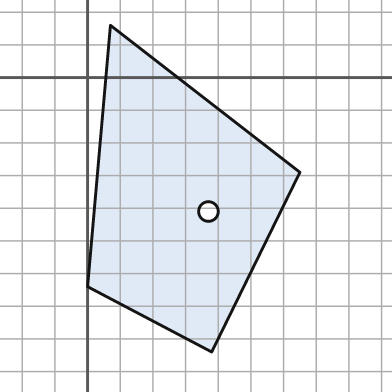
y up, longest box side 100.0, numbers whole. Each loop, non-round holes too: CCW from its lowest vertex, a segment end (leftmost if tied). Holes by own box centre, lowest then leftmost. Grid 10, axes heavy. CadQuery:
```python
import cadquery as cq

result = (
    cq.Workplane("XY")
    .moveTo(38.0, -84.0)
    .lineTo(65.0, -29.0)
    .lineTo(7.0, 16.0)
    .lineTo(0.0, -64.0)
    .close()
    .moveTo(37.0, -41.0)
    .circle(3.0)
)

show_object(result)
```